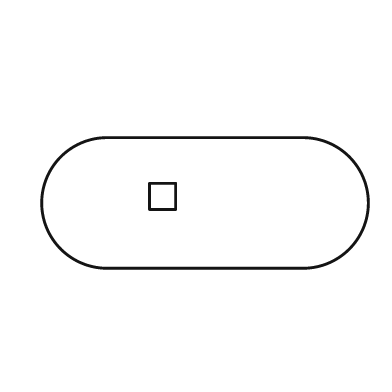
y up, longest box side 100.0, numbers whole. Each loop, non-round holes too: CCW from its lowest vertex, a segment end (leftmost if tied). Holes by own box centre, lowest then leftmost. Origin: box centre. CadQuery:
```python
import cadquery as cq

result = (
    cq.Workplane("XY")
    .moveTo(-30.0, -20.0)
    .lineTo(30.0, -20.0)
    .threePointArc((50.0, 0.0), (30.0, 20.0))
    .lineTo(-30.0, 20.0)
    .threePointArc((-50.0, 0.0), (-30.0, -20.0))
    .close()
    .moveTo(-17.0, -2.0)
    .lineTo(-9.0, -2.0)
    .lineTo(-9.0, 6.0)
    .lineTo(-17.0, 6.0)
    .close()
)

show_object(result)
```